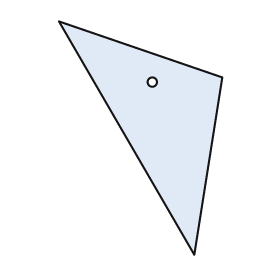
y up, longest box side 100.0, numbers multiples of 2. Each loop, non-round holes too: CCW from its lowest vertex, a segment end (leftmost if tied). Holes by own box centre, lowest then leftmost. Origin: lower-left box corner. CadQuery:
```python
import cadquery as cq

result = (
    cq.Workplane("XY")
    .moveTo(58.0, 0.0)
    .lineTo(70.0, 76.0)
    .lineTo(0.0, 100.0)
    .close()
    .moveTo(40.0, 74.0)
    .circle(2.0)
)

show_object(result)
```